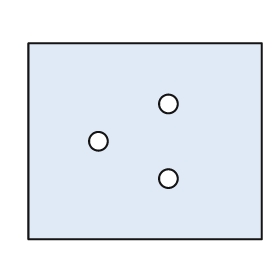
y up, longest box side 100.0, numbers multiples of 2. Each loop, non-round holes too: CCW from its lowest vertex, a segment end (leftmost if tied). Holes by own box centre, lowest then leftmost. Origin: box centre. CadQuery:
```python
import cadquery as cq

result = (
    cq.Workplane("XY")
    .moveTo(-50.0, -42.0)
    .lineTo(50.0, -42.0)
    .lineTo(50.0, 42.0)
    .lineTo(-50.0, 42.0)
    .close()
    .moveTo(10.0, -16.0)
    .circle(4.0)
    .moveTo(-20.0, 0.0)
    .circle(4.0)
    .moveTo(10.0, 16.0)
    .circle(4.0)
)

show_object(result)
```